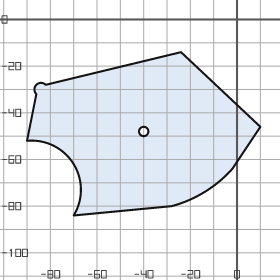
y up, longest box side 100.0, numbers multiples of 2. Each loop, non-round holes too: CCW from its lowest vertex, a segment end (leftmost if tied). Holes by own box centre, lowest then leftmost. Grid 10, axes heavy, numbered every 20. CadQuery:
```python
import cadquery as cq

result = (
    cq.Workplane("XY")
    .moveTo(-70.0, -84.0)
    .lineTo(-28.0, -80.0)
    .threePointArc((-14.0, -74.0), (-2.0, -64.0))
    .lineTo(10.0, -46.0)
    .lineTo(-24.0, -14.0)
    .lineTo(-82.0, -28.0)
    .threePointArc((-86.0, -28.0), (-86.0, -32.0))
    .lineTo(-90.0, -52.0)
    .threePointArc((-70.0, -62.0), (-70.0, -84.0))
    .close()
    .moveTo(-40.0, -48.0)
    .circle(2.0)
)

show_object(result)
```